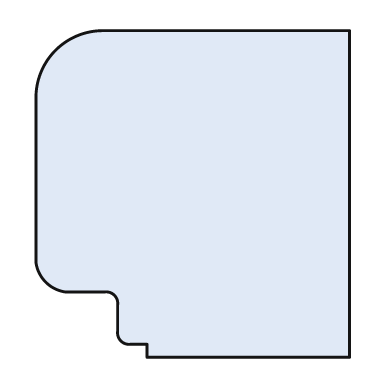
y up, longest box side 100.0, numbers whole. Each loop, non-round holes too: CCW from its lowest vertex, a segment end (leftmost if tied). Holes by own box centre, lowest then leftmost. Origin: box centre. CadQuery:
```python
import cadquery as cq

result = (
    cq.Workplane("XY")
    .moveTo(-14.0, -50.0)
    .lineTo(48.0, -50.0)
    .lineTo(48.0, 50.0)
    .lineTo(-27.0, 50.0)
    .threePointArc((-42.0, 44.0), (-48.0, 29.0))
    .lineTo(-48.0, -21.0)
    .threePointArc((-45.0, -27.0), (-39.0, -30.0))
    .lineTo(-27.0, -30.0)
    .threePointArc((-24.0, -31.0), (-23.0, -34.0))
    .lineTo(-23.0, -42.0)
    .threePointArc((-22.0, -45.0), (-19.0, -46.0))
    .lineTo(-14.0, -46.0)
    .close()
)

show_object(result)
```